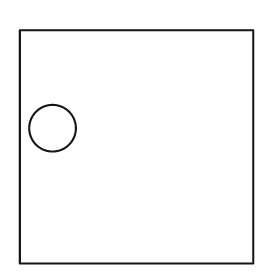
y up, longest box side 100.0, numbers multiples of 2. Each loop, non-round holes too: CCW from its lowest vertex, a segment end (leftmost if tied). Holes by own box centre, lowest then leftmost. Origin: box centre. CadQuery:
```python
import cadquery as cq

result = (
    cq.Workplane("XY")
    .moveTo(-50.0, -50.0)
    .lineTo(50.0, -50.0)
    .lineTo(50.0, 50.0)
    .lineTo(-50.0, 50.0)
    .close()
    .moveTo(-36.0, 8.0)
    .circle(10.0)
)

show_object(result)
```